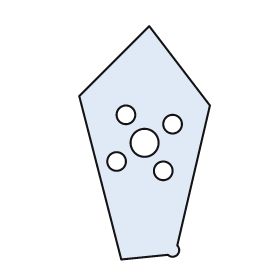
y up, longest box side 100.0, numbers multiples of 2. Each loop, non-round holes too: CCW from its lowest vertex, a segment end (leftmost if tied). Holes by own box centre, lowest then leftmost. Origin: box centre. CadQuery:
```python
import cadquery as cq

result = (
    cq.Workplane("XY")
    .moveTo(-10.0, -50.0)
    .lineTo(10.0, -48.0)
    .threePointArc((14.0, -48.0), (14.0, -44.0))
    .lineTo(28.0, 16.0)
    .lineTo(2.0, 50.0)
    .lineTo(-28.0, 20.0)
    .close()
    .moveTo(8.0, -12.0)
    .circle(4.0)
    .moveTo(-12.0, -8.0)
    .circle(4.0)
    .moveTo(0.0, 0.0)
    .circle(6.0)
    .moveTo(12.0, 8.0)
    .circle(4.0)
    .moveTo(-8.0, 12.0)
    .circle(4.0)
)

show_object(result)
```